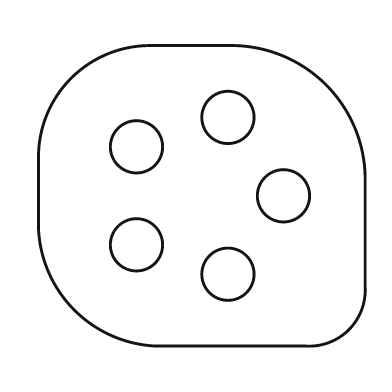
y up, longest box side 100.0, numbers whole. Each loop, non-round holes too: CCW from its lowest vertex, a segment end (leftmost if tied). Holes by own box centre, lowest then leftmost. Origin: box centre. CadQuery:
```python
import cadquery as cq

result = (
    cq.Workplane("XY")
    .moveTo(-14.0, -46.0)
    .lineTo(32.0, -46.0)
    .threePointArc((45.0, -41.0), (50.0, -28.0))
    .lineTo(50.0, 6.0)
    .threePointArc((38.0, 34.0), (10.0, 46.0))
    .lineTo(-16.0, 46.0)
    .threePointArc((-40.0, 36.0), (-50.0, 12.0))
    .lineTo(-50.0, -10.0)
    .threePointArc((-39.0, -35.0), (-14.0, -46.0))
    .close()
    .moveTo(8.0, -24.0)
    .circle(8.0)
    .moveTo(-20.0, -15.0)
    .circle(8.0)
    .moveTo(25.0, 0.0)
    .circle(8.0)
    .moveTo(-20.0, 15.0)
    .circle(8.0)
    .moveTo(8.0, 24.0)
    .circle(8.0)
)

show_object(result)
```